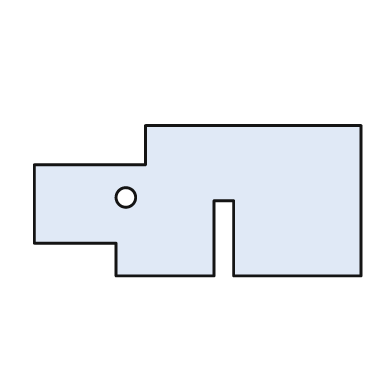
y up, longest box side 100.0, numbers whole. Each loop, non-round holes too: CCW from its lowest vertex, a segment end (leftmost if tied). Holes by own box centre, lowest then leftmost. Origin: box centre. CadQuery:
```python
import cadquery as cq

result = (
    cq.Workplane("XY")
    .moveTo(-25.0, -23.0)
    .lineTo(5.0, -23.0)
    .lineTo(5.0, 0.0)
    .lineTo(11.0, 0.0)
    .lineTo(11.0, -23.0)
    .lineTo(50.0, -23.0)
    .lineTo(50.0, 23.0)
    .lineTo(-16.0, 23.0)
    .lineTo(-16.0, 11.0)
    .lineTo(-50.0, 11.0)
    .lineTo(-50.0, -13.0)
    .lineTo(-25.0, -13.0)
    .close()
    .moveTo(-22.0, 1.0)
    .circle(3.0)
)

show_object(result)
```